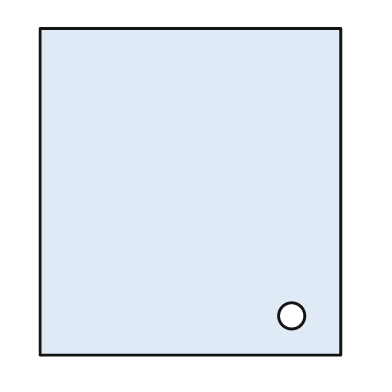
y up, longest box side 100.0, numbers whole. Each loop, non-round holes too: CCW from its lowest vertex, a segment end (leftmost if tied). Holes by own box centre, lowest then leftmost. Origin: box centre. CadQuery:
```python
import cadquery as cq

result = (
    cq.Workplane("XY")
    .moveTo(-46.0, -50.0)
    .lineTo(46.0, -50.0)
    .lineTo(46.0, 50.0)
    .lineTo(-46.0, 50.0)
    .close()
    .moveTo(31.0, -38.0)
    .circle(4.0)
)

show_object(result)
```